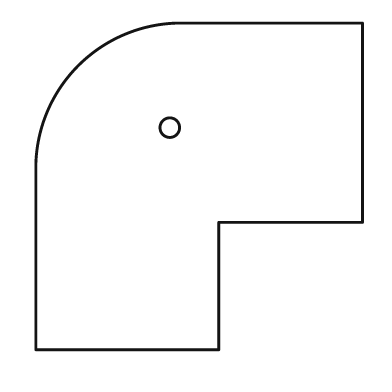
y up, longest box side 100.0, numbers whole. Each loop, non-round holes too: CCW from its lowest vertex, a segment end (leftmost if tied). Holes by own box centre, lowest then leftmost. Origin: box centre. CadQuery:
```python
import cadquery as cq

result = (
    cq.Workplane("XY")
    .moveTo(-50.0, -50.0)
    .lineTo(6.0, -50.0)
    .lineTo(6.0, -11.0)
    .lineTo(50.0, -11.0)
    .lineTo(50.0, 50.0)
    .lineTo(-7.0, 50.0)
    .threePointArc((-37.0, 37.0), (-50.0, 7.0))
    .close()
    .moveTo(-9.0, 18.0)
    .circle(3.0)
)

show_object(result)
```